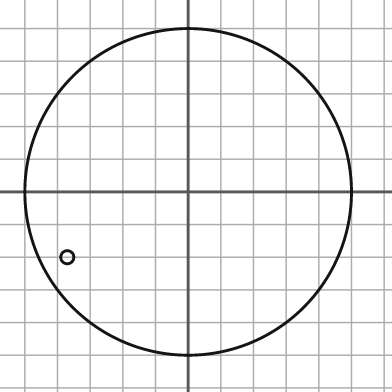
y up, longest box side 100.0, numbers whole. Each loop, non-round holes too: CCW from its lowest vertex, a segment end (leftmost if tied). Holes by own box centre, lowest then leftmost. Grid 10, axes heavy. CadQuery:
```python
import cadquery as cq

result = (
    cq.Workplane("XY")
    .moveTo(0.0, 0.0)
    .circle(50.0)
    .moveTo(-37.0, -20.0)
    .circle(2.0)
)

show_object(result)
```